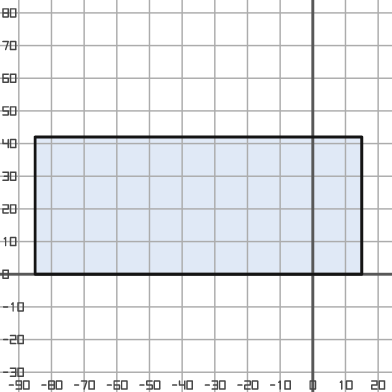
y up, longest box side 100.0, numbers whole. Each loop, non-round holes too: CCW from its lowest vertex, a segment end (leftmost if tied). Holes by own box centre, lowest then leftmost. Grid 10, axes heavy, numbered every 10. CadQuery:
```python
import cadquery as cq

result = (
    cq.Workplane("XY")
    .moveTo(-85.0, 0.0)
    .lineTo(15.0, 0.0)
    .lineTo(15.0, 42.0)
    .lineTo(-85.0, 42.0)
    .close()
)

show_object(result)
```